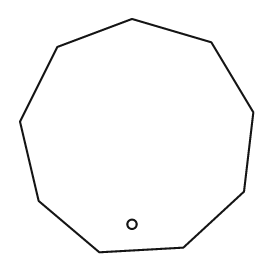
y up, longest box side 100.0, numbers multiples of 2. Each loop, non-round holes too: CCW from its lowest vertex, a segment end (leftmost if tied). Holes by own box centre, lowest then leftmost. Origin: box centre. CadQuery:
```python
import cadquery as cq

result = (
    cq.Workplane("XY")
    .moveTo(-16.0, -50.0)
    .lineTo(20.0, -48.0)
    .lineTo(46.0, -24.0)
    .lineTo(50.0, 10.0)
    .lineTo(32.0, 40.0)
    .lineTo(-2.0, 50.0)
    .lineTo(-34.0, 38.0)
    .lineTo(-50.0, 6.0)
    .lineTo(-42.0, -28.0)
    .close()
    .moveTo(-2.0, -38.0)
    .circle(2.0)
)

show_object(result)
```